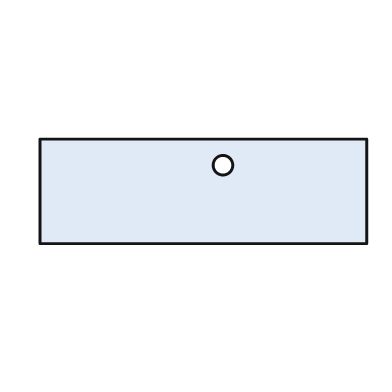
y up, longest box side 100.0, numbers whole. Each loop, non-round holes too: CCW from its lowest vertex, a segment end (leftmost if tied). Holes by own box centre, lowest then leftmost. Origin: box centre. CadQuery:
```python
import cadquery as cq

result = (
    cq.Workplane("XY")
    .moveTo(-50.0, -16.0)
    .lineTo(50.0, -16.0)
    .lineTo(50.0, 16.0)
    .lineTo(-50.0, 16.0)
    .close()
    .moveTo(6.0, 8.0)
    .circle(3.0)
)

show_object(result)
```